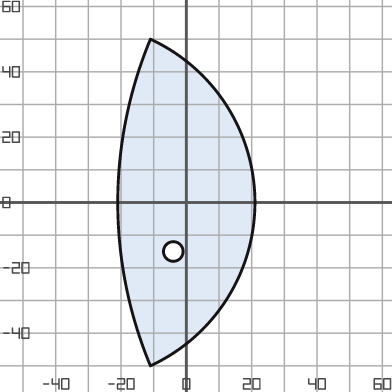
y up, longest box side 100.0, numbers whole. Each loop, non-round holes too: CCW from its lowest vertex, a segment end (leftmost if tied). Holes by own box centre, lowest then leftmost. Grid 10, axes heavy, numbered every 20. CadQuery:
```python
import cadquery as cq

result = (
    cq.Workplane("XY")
    .moveTo(-11.0, -50.0)
    .threePointArc((21.0, 0.0), (-11.0, 50.0))
    .threePointArc((-21.0, 0.0), (-11.0, -50.0))
    .close()
    .moveTo(-4.0, -15.0)
    .circle(3.0)
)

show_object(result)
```